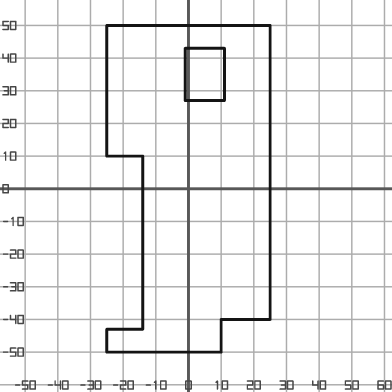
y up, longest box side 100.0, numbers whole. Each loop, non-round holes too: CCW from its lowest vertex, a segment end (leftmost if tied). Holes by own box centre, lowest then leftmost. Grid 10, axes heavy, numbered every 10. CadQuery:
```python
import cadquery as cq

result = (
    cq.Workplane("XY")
    .moveTo(-25.0, -50.0)
    .lineTo(10.0, -50.0)
    .lineTo(10.0, -40.0)
    .lineTo(25.0, -40.0)
    .lineTo(25.0, 50.0)
    .lineTo(-25.0, 50.0)
    .lineTo(-25.0, 10.0)
    .lineTo(-14.0, 10.0)
    .lineTo(-14.0, -43.0)
    .lineTo(-25.0, -43.0)
    .close()
    .moveTo(-1.0, 27.0)
    .lineTo(11.0, 27.0)
    .lineTo(11.0, 43.0)
    .lineTo(-1.0, 43.0)
    .close()
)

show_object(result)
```